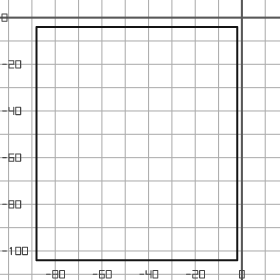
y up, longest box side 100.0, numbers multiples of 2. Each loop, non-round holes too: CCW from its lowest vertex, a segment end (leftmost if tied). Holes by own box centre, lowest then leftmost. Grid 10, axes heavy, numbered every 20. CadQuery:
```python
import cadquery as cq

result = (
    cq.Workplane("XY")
    .moveTo(-88.0, -104.0)
    .lineTo(-2.0, -104.0)
    .lineTo(-2.0, -4.0)
    .lineTo(-88.0, -4.0)
    .close()
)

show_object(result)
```